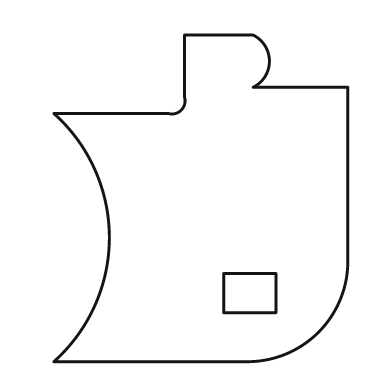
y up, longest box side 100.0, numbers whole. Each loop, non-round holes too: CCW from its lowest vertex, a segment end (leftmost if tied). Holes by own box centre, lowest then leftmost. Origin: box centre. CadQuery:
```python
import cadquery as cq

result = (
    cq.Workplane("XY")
    .moveTo(-45.0, -50.0)
    .lineTo(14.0, -50.0)
    .threePointArc((36.0, -41.0), (45.0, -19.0))
    .lineTo(45.0, 34.0)
    .lineTo(16.0, 34.0)
    .threePointArc((21.0, 42.0), (16.0, 50.0))
    .lineTo(-5.0, 50.0)
    .lineTo(-5.0, 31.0)
    .threePointArc((-6.0, 27.0), (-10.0, 26.0))
    .lineTo(-45.0, 26.0)
    .threePointArc((-28.0, -12.0), (-45.0, -50.0))
    .close()
    .moveTo(7.0, -35.0)
    .lineTo(23.0, -35.0)
    .lineTo(23.0, -23.0)
    .lineTo(7.0, -23.0)
    .close()
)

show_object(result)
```